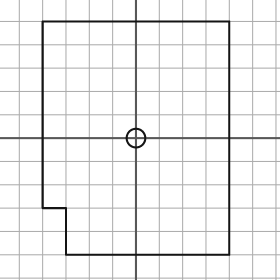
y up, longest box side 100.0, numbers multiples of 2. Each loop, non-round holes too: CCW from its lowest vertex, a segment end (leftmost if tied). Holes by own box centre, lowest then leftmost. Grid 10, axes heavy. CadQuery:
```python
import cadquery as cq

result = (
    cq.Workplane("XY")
    .moveTo(-30.0, -50.0)
    .lineTo(40.0, -50.0)
    .lineTo(40.0, 50.0)
    .lineTo(-40.0, 50.0)
    .lineTo(-40.0, -30.0)
    .lineTo(-30.0, -30.0)
    .close()
    .moveTo(0.0, 0.0)
    .circle(4.0)
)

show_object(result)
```